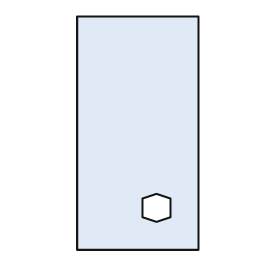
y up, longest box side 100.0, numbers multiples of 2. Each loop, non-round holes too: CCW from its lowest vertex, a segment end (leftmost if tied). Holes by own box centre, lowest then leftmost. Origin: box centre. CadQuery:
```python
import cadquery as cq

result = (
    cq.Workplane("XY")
    .moveTo(-26.0, -50.0)
    .lineTo(26.0, -50.0)
    .lineTo(26.0, 50.0)
    .lineTo(-26.0, 50.0)
    .close()
    .moveTo(8.0, -38.0)
    .lineTo(14.0, -36.0)
    .lineTo(14.0, -28.0)
    .lineTo(8.0, -26.0)
    .lineTo(2.0, -28.0)
    .lineTo(2.0, -36.0)
    .close()
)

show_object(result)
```